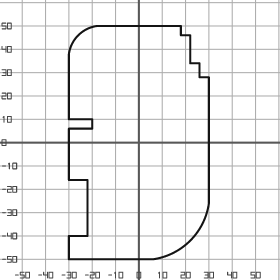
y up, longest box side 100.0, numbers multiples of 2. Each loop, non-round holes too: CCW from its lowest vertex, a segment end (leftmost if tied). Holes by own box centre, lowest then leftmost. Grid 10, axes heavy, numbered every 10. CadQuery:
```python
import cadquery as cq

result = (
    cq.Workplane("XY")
    .moveTo(-30.0, -50.0)
    .lineTo(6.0, -50.0)
    .threePointArc((22.0, -42.0), (30.0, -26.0))
    .lineTo(30.0, 28.0)
    .lineTo(26.0, 28.0)
    .lineTo(26.0, 34.0)
    .lineTo(22.0, 34.0)
    .lineTo(22.0, 46.0)
    .lineTo(18.0, 46.0)
    .lineTo(18.0, 50.0)
    .lineTo(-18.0, 50.0)
    .threePointArc((-26.0, 46.0), (-30.0, 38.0))
    .lineTo(-30.0, 10.0)
    .lineTo(-20.0, 10.0)
    .lineTo(-20.0, 6.0)
    .lineTo(-30.0, 6.0)
    .lineTo(-30.0, -16.0)
    .lineTo(-22.0, -16.0)
    .lineTo(-22.0, -40.0)
    .lineTo(-30.0, -40.0)
    .close()
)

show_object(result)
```